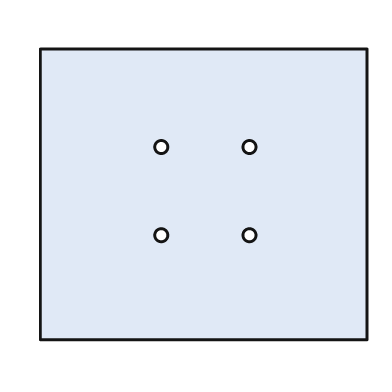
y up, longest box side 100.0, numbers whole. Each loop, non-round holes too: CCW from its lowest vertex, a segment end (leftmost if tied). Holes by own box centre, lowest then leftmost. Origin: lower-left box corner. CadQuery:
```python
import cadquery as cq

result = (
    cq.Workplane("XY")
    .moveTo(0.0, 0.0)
    .lineTo(100.0, 0.0)
    .lineTo(100.0, 89.0)
    .lineTo(0.0, 89.0)
    .close()
    .moveTo(37.0, 32.0)
    .circle(2.0)
    .moveTo(64.0, 32.0)
    .circle(2.0)
    .moveTo(37.0, 59.0)
    .circle(2.0)
    .moveTo(64.0, 59.0)
    .circle(2.0)
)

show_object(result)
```